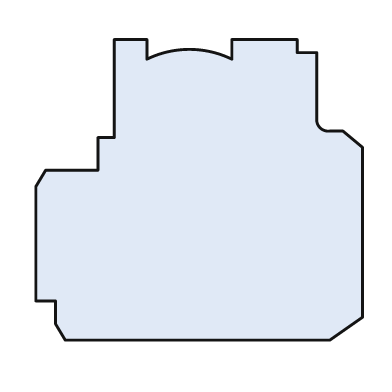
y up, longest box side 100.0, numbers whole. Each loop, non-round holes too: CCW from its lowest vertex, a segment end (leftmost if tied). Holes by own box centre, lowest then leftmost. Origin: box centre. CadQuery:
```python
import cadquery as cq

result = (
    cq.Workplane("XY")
    .moveTo(-41.0, -46.0)
    .lineTo(40.0, -46.0)
    .lineTo(50.0, -39.0)
    .lineTo(50.0, 13.0)
    .lineTo(44.0, 18.0)
    .lineTo(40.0, 18.0)
    .threePointArc((37.0, 19.0), (36.0, 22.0))
    .lineTo(36.0, 42.0)
    .lineTo(30.0, 42.0)
    .lineTo(30.0, 46.0)
    .lineTo(10.0, 46.0)
    .lineTo(10.0, 40.0)
    .threePointArc((-3.0, 43.0), (-16.0, 40.0))
    .lineTo(-16.0, 46.0)
    .lineTo(-26.0, 46.0)
    .lineTo(-26.0, 16.0)
    .lineTo(-31.0, 16.0)
    .lineTo(-31.0, 6.0)
    .lineTo(-47.0, 6.0)
    .lineTo(-50.0, 1.0)
    .lineTo(-50.0, -34.0)
    .lineTo(-44.0, -34.0)
    .lineTo(-44.0, -41.0)
    .close()
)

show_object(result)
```